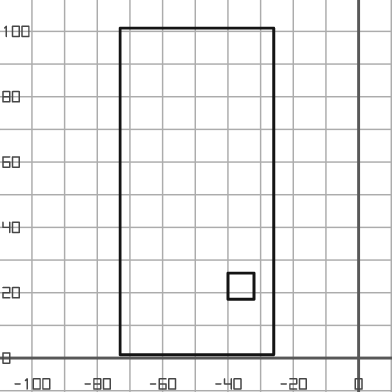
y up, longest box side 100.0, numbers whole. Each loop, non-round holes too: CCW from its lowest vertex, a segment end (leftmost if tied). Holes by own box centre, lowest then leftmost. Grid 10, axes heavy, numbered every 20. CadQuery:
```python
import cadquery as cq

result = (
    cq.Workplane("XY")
    .moveTo(-73.0, 1.0)
    .lineTo(-26.0, 1.0)
    .lineTo(-26.0, 101.0)
    .lineTo(-73.0, 101.0)
    .close()
    .moveTo(-40.0, 18.0)
    .lineTo(-32.0, 18.0)
    .lineTo(-32.0, 26.0)
    .lineTo(-40.0, 26.0)
    .close()
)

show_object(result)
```